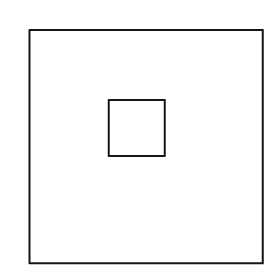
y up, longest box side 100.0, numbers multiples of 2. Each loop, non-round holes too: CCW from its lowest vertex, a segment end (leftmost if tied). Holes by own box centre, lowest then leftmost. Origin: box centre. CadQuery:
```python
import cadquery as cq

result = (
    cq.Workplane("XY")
    .moveTo(-50.0, -50.0)
    .lineTo(50.0, -50.0)
    .lineTo(50.0, 50.0)
    .lineTo(-50.0, 50.0)
    .close()
    .moveTo(-16.0, -4.0)
    .lineTo(8.0, -4.0)
    .lineTo(8.0, 20.0)
    .lineTo(-16.0, 20.0)
    .close()
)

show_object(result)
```